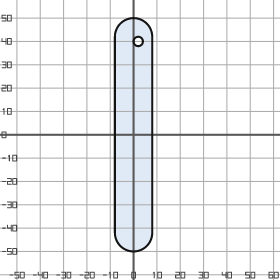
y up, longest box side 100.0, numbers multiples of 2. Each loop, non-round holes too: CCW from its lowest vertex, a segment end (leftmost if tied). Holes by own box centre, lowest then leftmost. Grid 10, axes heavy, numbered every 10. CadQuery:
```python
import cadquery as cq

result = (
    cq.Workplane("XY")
    .moveTo(-8.0, -42.0)
    .threePointArc((0.0, -50.0), (8.0, -42.0))
    .lineTo(8.0, 42.0)
    .threePointArc((0.0, 50.0), (-8.0, 42.0))
    .close()
    .moveTo(2.0, 40.0)
    .circle(2.0)
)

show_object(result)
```